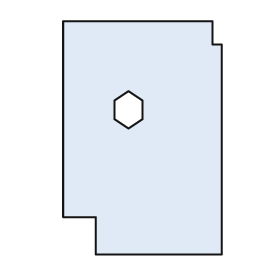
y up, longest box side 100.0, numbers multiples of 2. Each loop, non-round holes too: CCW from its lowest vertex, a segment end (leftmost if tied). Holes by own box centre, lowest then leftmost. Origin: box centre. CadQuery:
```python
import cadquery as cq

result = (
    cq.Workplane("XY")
    .moveTo(-20.0, -50.0)
    .lineTo(34.0, -50.0)
    .lineTo(34.0, 40.0)
    .lineTo(30.0, 40.0)
    .lineTo(30.0, 50.0)
    .lineTo(-34.0, 50.0)
    .lineTo(-34.0, -34.0)
    .lineTo(-20.0, -34.0)
    .close()
    .moveTo(-6.0, 4.0)
    .lineTo(0.0, 8.0)
    .lineTo(0.0, 16.0)
    .lineTo(-6.0, 20.0)
    .lineTo(-12.0, 16.0)
    .lineTo(-12.0, 8.0)
    .close()
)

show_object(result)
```